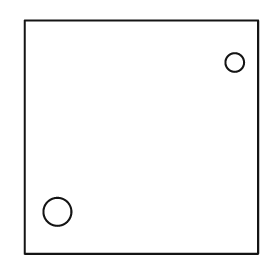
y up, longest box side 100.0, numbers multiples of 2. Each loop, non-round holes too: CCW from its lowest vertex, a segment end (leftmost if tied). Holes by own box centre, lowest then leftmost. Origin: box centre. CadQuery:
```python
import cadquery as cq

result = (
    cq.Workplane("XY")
    .moveTo(-50.0, -50.0)
    .lineTo(50.0, -50.0)
    .lineTo(50.0, 50.0)
    .lineTo(-50.0, 50.0)
    .close()
    .moveTo(-36.0, -32.0)
    .circle(6.0)
    .moveTo(40.0, 32.0)
    .circle(4.0)
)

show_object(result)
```